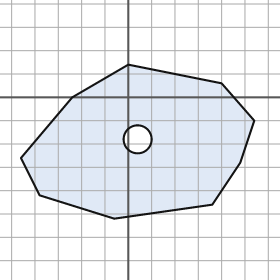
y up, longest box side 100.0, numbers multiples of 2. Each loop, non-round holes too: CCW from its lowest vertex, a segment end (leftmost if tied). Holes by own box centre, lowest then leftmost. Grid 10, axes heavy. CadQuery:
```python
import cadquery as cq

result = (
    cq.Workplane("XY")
    .moveTo(-6.0, -52.0)
    .lineTo(36.0, -46.0)
    .lineTo(48.0, -28.0)
    .lineTo(54.0, -10.0)
    .lineTo(40.0, 6.0)
    .lineTo(0.0, 14.0)
    .lineTo(-24.0, 0.0)
    .lineTo(-46.0, -26.0)
    .lineTo(-38.0, -42.0)
    .close()
    .moveTo(4.0, -18.0)
    .circle(6.0)
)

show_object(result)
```